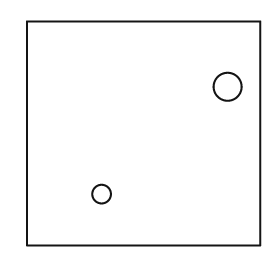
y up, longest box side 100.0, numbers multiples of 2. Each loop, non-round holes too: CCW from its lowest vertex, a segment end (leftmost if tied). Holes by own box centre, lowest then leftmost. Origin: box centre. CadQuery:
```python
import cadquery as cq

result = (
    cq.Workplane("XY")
    .moveTo(-50.0, -48.0)
    .lineTo(50.0, -48.0)
    .lineTo(50.0, 48.0)
    .lineTo(-50.0, 48.0)
    .close()
    .moveTo(-18.0, -26.0)
    .circle(4.0)
    .moveTo(36.0, 20.0)
    .circle(6.0)
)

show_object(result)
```